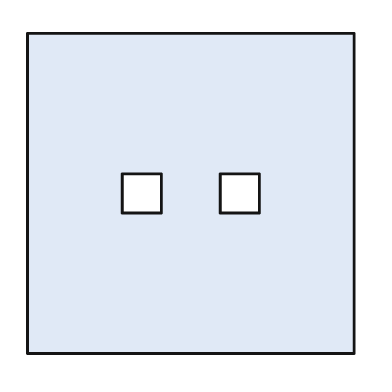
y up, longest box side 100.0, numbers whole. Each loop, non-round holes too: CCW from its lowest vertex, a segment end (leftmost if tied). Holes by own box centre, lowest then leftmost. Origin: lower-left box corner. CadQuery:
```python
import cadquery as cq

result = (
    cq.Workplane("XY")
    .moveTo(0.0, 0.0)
    .lineTo(100.0, 0.0)
    .lineTo(100.0, 98.0)
    .lineTo(0.0, 98.0)
    .close()
    .moveTo(29.0, 43.0)
    .lineTo(41.0, 43.0)
    .lineTo(41.0, 55.0)
    .lineTo(29.0, 55.0)
    .close()
    .moveTo(59.0, 43.0)
    .lineTo(71.0, 43.0)
    .lineTo(71.0, 55.0)
    .lineTo(59.0, 55.0)
    .close()
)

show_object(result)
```